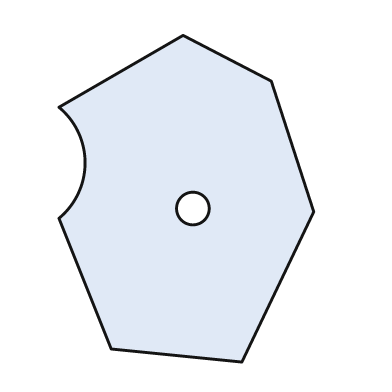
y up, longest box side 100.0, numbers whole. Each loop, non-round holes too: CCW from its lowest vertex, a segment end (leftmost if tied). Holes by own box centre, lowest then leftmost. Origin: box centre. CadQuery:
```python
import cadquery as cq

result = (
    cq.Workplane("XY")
    .moveTo(17.0, -50.0)
    .lineTo(39.0, -4.0)
    .lineTo(26.0, 36.0)
    .lineTo(-1.0, 50.0)
    .lineTo(-39.0, 28.0)
    .threePointArc((-31.0, 11.0), (-39.0, -6.0))
    .lineTo(-23.0, -46.0)
    .close()
    .moveTo(2.0, -3.0)
    .circle(5.0)
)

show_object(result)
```